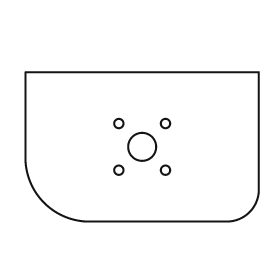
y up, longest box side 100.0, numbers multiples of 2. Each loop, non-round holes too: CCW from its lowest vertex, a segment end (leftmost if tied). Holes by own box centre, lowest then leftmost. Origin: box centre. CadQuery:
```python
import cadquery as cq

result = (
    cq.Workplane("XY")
    .moveTo(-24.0, -32.0)
    .lineTo(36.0, -32.0)
    .threePointArc((46.0, -28.0), (50.0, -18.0))
    .lineTo(50.0, 32.0)
    .lineTo(-50.0, 32.0)
    .lineTo(-50.0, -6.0)
    .threePointArc((-42.0, -24.0), (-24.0, -32.0))
    .close()
    .moveTo(-10.0, -10.0)
    .circle(2.0)
    .moveTo(10.0, -10.0)
    .circle(2.0)
    .moveTo(0.0, 0.0)
    .circle(6.0)
    .moveTo(-10.0, 10.0)
    .circle(2.0)
    .moveTo(10.0, 10.0)
    .circle(2.0)
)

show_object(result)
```